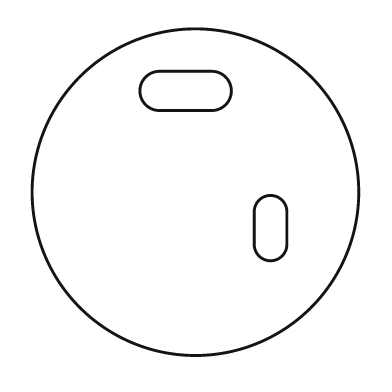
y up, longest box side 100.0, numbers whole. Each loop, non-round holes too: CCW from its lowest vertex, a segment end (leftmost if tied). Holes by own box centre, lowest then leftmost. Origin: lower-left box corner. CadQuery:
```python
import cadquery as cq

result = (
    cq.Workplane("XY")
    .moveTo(50.0, 50.0)
    .circle(50.0)
    .moveTo(68.0, 34.0)
    .threePointArc((73.0, 29.0), (78.0, 34.0))
    .lineTo(78.0, 44.0)
    .threePointArc((73.0, 49.0), (68.0, 44.0))
    .close()
    .moveTo(39.0, 75.0)
    .lineTo(55.0, 75.0)
    .threePointArc((61.0, 81.0), (55.0, 87.0))
    .lineTo(39.0, 87.0)
    .threePointArc((33.0, 81.0), (39.0, 75.0))
    .close()
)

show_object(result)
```